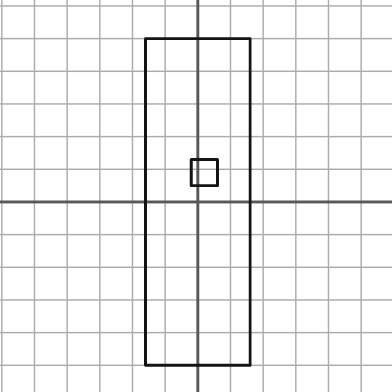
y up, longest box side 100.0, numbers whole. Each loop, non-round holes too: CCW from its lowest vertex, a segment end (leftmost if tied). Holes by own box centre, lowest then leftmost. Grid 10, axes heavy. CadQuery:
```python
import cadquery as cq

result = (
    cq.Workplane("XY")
    .moveTo(-16.0, -50.0)
    .lineTo(16.0, -50.0)
    .lineTo(16.0, 50.0)
    .lineTo(-16.0, 50.0)
    .close()
    .moveTo(-2.0, 5.0)
    .lineTo(6.0, 5.0)
    .lineTo(6.0, 13.0)
    .lineTo(-2.0, 13.0)
    .close()
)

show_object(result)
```